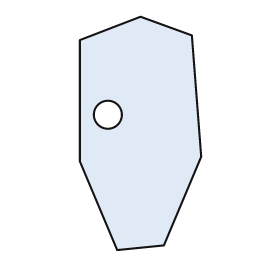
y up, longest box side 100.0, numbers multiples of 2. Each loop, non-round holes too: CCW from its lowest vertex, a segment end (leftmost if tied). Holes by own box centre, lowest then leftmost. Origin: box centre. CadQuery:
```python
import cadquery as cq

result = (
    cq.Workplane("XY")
    .moveTo(-10.0, -50.0)
    .lineTo(10.0, -48.0)
    .lineTo(26.0, -10.0)
    .lineTo(22.0, 42.0)
    .lineTo(0.0, 50.0)
    .lineTo(-26.0, 40.0)
    .lineTo(-26.0, -12.0)
    .close()
    .moveTo(-14.0, 8.0)
    .circle(6.0)
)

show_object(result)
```